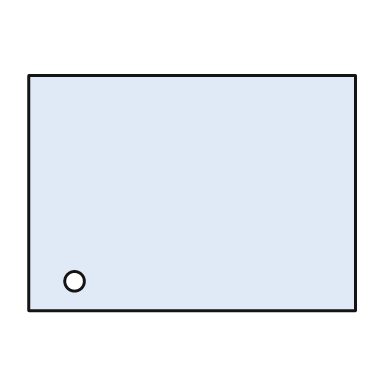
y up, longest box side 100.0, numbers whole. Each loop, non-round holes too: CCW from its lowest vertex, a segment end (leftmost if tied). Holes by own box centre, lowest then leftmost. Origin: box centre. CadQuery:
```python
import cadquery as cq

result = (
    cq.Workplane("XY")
    .moveTo(-50.0, -36.0)
    .lineTo(50.0, -36.0)
    .lineTo(50.0, 36.0)
    .lineTo(-50.0, 36.0)
    .close()
    .moveTo(-36.0, -27.0)
    .circle(3.0)
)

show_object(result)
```